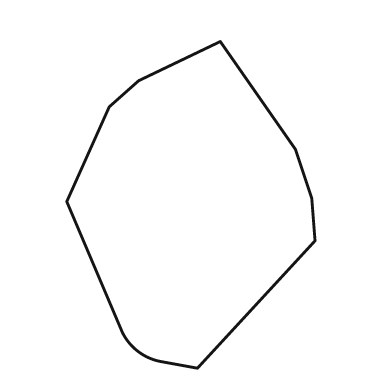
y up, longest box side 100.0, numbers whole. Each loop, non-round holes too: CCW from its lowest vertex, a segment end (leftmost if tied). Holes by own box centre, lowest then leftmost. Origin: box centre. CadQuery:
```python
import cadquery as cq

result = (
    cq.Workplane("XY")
    .moveTo(2.0, -50.0)
    .lineTo(38.0, -11.0)
    .lineTo(37.0, 2.0)
    .lineTo(32.0, 17.0)
    .lineTo(9.0, 50.0)
    .lineTo(-16.0, 38.0)
    .lineTo(-25.0, 30.0)
    .lineTo(-38.0, 1.0)
    .lineTo(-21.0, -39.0)
    .threePointArc((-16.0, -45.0), (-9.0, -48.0))
    .close()
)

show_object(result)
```